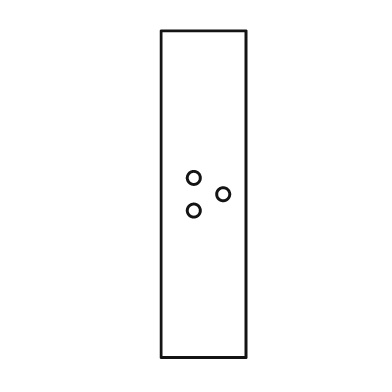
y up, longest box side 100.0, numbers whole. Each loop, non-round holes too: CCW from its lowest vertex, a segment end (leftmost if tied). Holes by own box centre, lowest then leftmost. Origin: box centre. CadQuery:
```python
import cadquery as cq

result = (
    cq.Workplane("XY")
    .moveTo(-13.0, -50.0)
    .lineTo(13.0, -50.0)
    .lineTo(13.0, 50.0)
    .lineTo(-13.0, 50.0)
    .close()
    .moveTo(-3.0, -5.0)
    .circle(2.0)
    .moveTo(6.0, 0.0)
    .circle(2.0)
    .moveTo(-3.0, 5.0)
    .circle(2.0)
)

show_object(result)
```